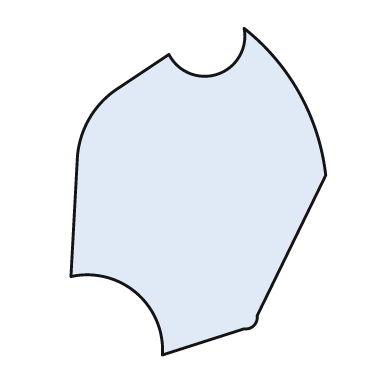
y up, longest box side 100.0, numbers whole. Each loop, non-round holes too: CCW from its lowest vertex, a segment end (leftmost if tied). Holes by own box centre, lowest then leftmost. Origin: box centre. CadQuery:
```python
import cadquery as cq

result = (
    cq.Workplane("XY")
    .moveTo(-11.0, -50.0)
    .lineTo(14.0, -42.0)
    .threePointArc((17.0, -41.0), (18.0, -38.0))
    .lineTo(39.0, 5.0)
    .threePointArc((31.0, 30.0), (14.0, 50.0))
    .threePointArc((6.0, 36.0), (-9.0, 42.0))
    .lineTo(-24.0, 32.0)
    .threePointArc((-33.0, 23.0), (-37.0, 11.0))
    .lineTo(-39.0, -26.0)
    .threePointArc((-19.0, -31.0), (-11.0, -50.0))
    .close()
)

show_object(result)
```